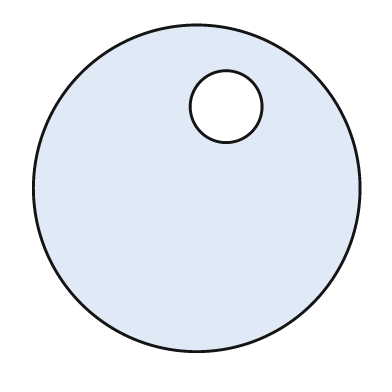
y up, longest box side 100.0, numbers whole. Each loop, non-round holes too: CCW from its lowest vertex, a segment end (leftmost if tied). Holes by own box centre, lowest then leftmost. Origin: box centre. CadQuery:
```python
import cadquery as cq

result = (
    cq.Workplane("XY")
    .moveTo(0.0, 0.0)
    .circle(50.0)
    .moveTo(9.0, 25.0)
    .circle(11.0)
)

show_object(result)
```